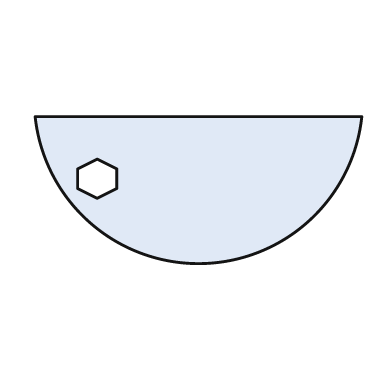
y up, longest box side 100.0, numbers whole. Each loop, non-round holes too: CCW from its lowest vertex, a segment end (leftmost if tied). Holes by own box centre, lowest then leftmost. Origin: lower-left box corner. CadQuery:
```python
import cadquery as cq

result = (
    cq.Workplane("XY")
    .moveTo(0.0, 45.0)
    .threePointArc((50.0, 0.0), (100.0, 45.0))
    .close()
    .moveTo(19.0, 20.0)
    .lineTo(25.0, 23.0)
    .lineTo(25.0, 29.0)
    .lineTo(19.0, 32.0)
    .lineTo(13.0, 29.0)
    .lineTo(13.0, 23.0)
    .close()
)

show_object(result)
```